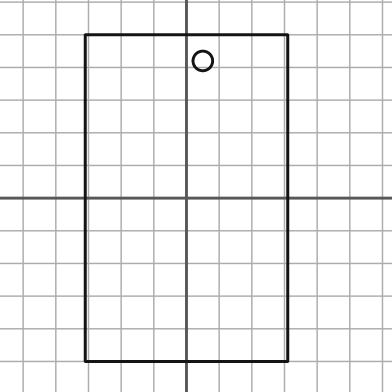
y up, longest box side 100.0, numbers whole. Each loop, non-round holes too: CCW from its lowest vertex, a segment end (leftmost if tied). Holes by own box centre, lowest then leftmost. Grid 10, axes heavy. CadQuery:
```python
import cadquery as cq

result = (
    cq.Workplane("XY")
    .moveTo(-31.0, -50.0)
    .lineTo(31.0, -50.0)
    .lineTo(31.0, 50.0)
    .lineTo(-31.0, 50.0)
    .close()
    .moveTo(5.0, 42.0)
    .circle(3.0)
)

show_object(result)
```